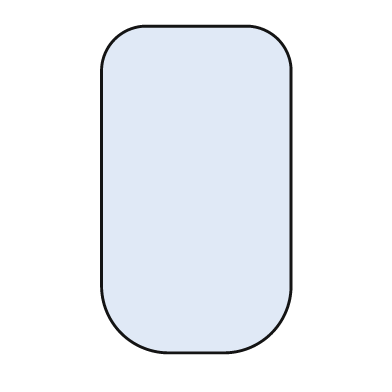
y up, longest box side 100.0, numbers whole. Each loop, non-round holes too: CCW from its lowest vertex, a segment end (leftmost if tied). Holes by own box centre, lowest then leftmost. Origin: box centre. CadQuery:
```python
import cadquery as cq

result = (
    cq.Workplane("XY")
    .moveTo(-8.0, -50.0)
    .lineTo(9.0, -50.0)
    .threePointArc((23.0, -44.0), (29.0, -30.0))
    .lineTo(29.0, 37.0)
    .threePointArc((25.0, 46.0), (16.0, 50.0))
    .lineTo(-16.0, 50.0)
    .threePointArc((-25.0, 46.0), (-29.0, 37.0))
    .lineTo(-29.0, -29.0)
    .threePointArc((-23.0, -44.0), (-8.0, -50.0))
    .close()
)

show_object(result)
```